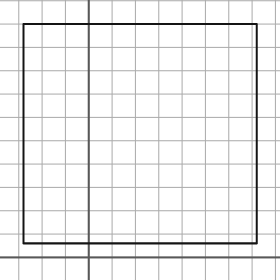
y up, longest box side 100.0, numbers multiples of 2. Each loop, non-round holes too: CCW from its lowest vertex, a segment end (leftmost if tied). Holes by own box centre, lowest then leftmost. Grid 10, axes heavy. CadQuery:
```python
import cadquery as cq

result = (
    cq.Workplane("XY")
    .moveTo(-28.0, 6.0)
    .lineTo(72.0, 6.0)
    .lineTo(72.0, 100.0)
    .lineTo(-28.0, 100.0)
    .close()
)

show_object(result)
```